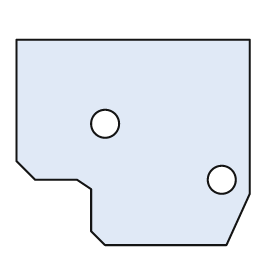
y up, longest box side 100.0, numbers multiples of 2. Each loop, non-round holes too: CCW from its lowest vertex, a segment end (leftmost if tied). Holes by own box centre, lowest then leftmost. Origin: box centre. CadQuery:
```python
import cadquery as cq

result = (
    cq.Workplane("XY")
    .moveTo(-12.0, -44.0)
    .lineTo(40.0, -44.0)
    .lineTo(50.0, -22.0)
    .lineTo(50.0, 44.0)
    .lineTo(-50.0, 44.0)
    .lineTo(-50.0, -8.0)
    .lineTo(-42.0, -16.0)
    .lineTo(-24.0, -16.0)
    .lineTo(-18.0, -20.0)
    .lineTo(-18.0, -38.0)
    .close()
    .moveTo(38.0, -16.0)
    .circle(6.0)
    .moveTo(-12.0, 8.0)
    .circle(6.0)
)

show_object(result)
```